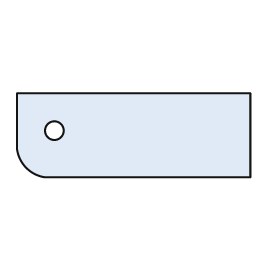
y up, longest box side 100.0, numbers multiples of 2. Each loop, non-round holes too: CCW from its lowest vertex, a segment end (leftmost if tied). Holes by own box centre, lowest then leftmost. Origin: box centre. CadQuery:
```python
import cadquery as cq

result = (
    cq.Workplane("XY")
    .moveTo(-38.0, -18.0)
    .lineTo(50.0, -18.0)
    .lineTo(50.0, 18.0)
    .lineTo(-50.0, 18.0)
    .lineTo(-50.0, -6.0)
    .threePointArc((-46.0, -14.0), (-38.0, -18.0))
    .close()
    .moveTo(-34.0, 2.0)
    .circle(4.0)
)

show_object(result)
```